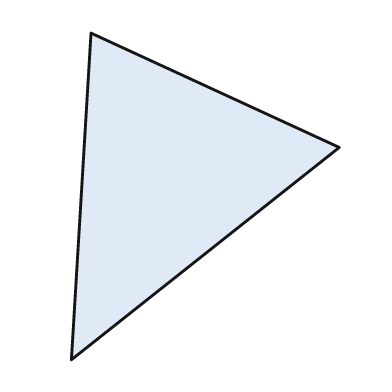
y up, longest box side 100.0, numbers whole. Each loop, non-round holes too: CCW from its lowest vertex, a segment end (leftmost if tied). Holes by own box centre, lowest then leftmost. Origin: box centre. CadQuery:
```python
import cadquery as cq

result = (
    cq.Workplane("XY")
    .moveTo(-41.0, -50.0)
    .lineTo(41.0, 15.0)
    .lineTo(-35.0, 50.0)
    .close()
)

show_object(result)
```